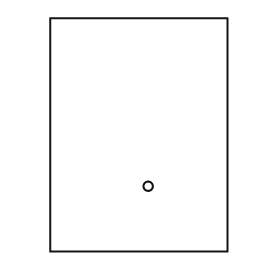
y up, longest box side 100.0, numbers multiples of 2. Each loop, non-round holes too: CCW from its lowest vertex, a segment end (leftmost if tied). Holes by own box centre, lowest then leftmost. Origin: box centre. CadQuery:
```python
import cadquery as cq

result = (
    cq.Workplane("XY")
    .moveTo(-38.0, -50.0)
    .lineTo(38.0, -50.0)
    .lineTo(38.0, 50.0)
    .lineTo(-38.0, 50.0)
    .close()
    .moveTo(4.0, -22.0)
    .circle(2.0)
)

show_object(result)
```